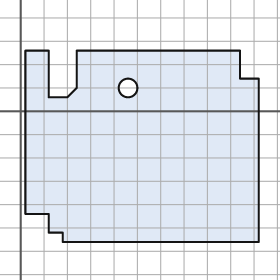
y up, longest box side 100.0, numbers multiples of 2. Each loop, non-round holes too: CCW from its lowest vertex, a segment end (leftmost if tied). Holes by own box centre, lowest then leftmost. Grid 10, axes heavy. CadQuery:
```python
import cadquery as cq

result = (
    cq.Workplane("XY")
    .moveTo(18.0, -56.0)
    .lineTo(102.0, -56.0)
    .lineTo(102.0, 14.0)
    .lineTo(94.0, 14.0)
    .lineTo(94.0, 26.0)
    .lineTo(24.0, 26.0)
    .lineTo(24.0, 10.0)
    .lineTo(20.0, 6.0)
    .lineTo(12.0, 6.0)
    .lineTo(12.0, 26.0)
    .lineTo(2.0, 26.0)
    .lineTo(2.0, -44.0)
    .lineTo(12.0, -44.0)
    .lineTo(12.0, -52.0)
    .lineTo(18.0, -52.0)
    .close()
    .moveTo(46.0, 10.0)
    .circle(4.0)
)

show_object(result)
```